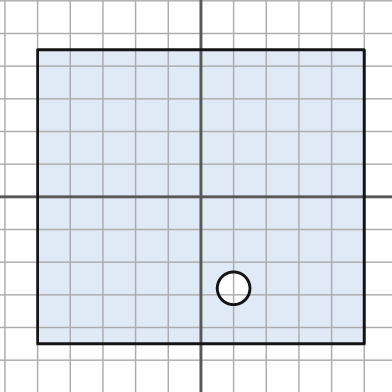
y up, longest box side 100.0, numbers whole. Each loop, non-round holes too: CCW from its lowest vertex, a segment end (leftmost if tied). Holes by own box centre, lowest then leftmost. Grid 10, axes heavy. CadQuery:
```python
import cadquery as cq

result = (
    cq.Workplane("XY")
    .moveTo(-50.0, -45.0)
    .lineTo(50.0, -45.0)
    .lineTo(50.0, 45.0)
    .lineTo(-50.0, 45.0)
    .close()
    .moveTo(10.0, -28.0)
    .circle(5.0)
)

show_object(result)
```